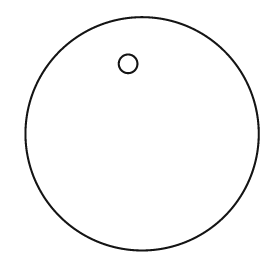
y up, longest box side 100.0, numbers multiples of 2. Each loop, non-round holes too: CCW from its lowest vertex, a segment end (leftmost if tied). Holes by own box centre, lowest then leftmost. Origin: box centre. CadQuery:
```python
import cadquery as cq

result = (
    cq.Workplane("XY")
    .moveTo(0.0, 0.0)
    .circle(50.0)
    .moveTo(-6.0, 30.0)
    .circle(4.0)
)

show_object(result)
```